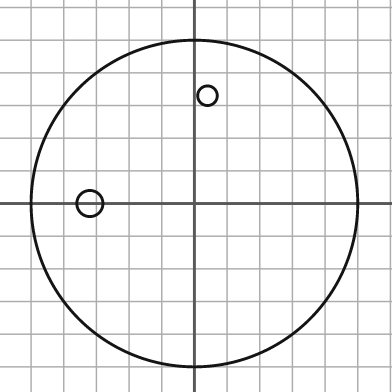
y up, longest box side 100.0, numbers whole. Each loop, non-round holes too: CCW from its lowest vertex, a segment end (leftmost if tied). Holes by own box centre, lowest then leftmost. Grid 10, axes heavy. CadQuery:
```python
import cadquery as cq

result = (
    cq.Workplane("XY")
    .moveTo(0.0, 0.0)
    .circle(50.0)
    .moveTo(-32.0, 0.0)
    .circle(4.0)
    .moveTo(4.0, 33.0)
    .circle(3.0)
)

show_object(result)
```